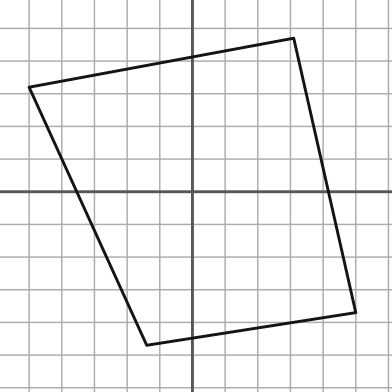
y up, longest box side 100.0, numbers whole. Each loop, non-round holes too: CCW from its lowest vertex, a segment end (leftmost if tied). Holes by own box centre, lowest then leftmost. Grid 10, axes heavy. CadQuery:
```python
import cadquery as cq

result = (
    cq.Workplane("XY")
    .moveTo(-14.0, -47.0)
    .lineTo(50.0, -37.0)
    .lineTo(31.0, 47.0)
    .lineTo(-50.0, 32.0)
    .close()
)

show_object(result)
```